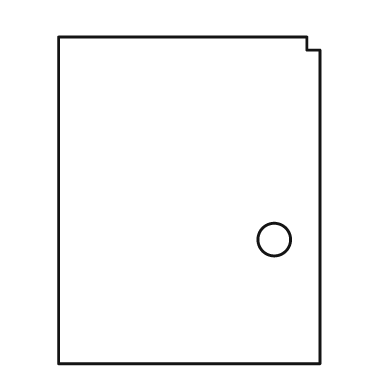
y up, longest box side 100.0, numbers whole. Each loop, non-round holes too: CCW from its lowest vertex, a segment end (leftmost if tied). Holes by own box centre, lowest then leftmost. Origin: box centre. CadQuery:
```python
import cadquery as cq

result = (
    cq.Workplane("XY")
    .moveTo(-40.0, -50.0)
    .lineTo(40.0, -50.0)
    .lineTo(40.0, 46.0)
    .lineTo(36.0, 46.0)
    .lineTo(36.0, 50.0)
    .lineTo(-40.0, 50.0)
    .close()
    .moveTo(26.0, -12.0)
    .circle(5.0)
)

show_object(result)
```